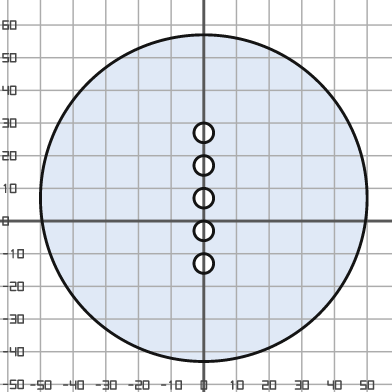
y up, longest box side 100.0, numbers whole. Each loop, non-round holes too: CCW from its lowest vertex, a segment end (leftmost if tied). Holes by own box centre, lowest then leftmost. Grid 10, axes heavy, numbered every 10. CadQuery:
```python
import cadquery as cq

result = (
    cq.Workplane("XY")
    .moveTo(0.0, 7.0)
    .circle(50.0)
    .moveTo(0.0, -13.0)
    .circle(3.0)
    .moveTo(0.0, -3.0)
    .circle(3.0)
    .moveTo(0.0, 7.0)
    .circle(3.0)
    .moveTo(0.0, 17.0)
    .circle(3.0)
    .moveTo(0.0, 27.0)
    .circle(3.0)
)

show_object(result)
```